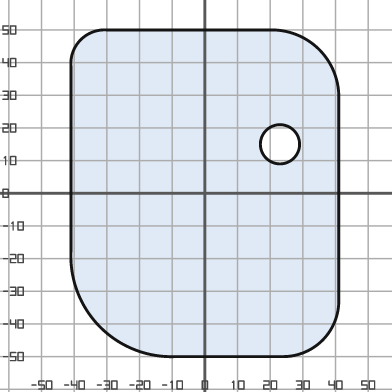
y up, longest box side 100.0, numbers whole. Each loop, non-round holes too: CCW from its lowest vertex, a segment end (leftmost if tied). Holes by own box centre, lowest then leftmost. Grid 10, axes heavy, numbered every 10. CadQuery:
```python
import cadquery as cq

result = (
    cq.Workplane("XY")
    .moveTo(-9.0, -50.0)
    .lineTo(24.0, -50.0)
    .threePointArc((36.0, -45.0), (41.0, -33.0))
    .lineTo(41.0, 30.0)
    .threePointArc((35.0, 44.0), (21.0, 50.0))
    .lineTo(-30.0, 50.0)
    .threePointArc((-38.0, 47.0), (-41.0, 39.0))
    .lineTo(-41.0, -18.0)
    .threePointArc((-32.0, -41.0), (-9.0, -50.0))
    .close()
    .moveTo(23.0, 15.0)
    .circle(6.0)
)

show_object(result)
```